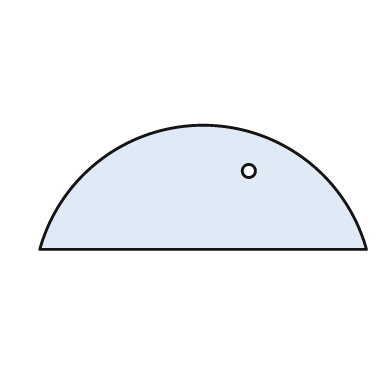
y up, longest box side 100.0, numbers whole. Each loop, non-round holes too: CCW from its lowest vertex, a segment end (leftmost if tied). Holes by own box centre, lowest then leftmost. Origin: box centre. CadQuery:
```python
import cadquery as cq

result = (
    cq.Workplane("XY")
    .moveTo(-50.0, -19.0)
    .lineTo(50.0, -19.0)
    .threePointArc((0.0, 19.0), (-50.0, -19.0))
    .close()
    .moveTo(14.0, 5.0)
    .circle(2.0)
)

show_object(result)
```